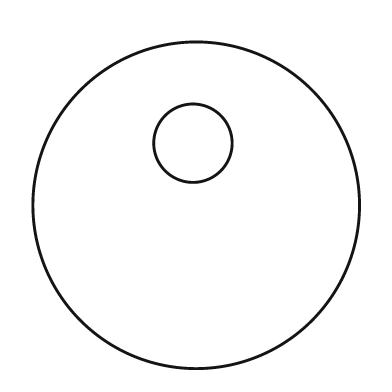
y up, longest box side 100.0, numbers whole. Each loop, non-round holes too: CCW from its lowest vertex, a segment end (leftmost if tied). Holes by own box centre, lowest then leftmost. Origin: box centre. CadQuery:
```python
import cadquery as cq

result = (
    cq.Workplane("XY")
    .moveTo(0.0, 0.0)
    .circle(50.0)
    .moveTo(-1.0, 19.0)
    .circle(12.0)
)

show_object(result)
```